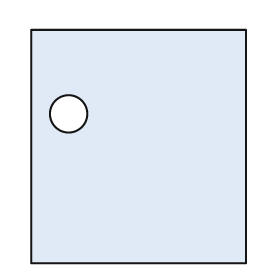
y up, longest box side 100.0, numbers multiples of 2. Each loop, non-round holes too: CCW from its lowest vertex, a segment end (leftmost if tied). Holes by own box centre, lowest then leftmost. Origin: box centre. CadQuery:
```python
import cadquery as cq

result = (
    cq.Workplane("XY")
    .moveTo(-46.0, -50.0)
    .lineTo(46.0, -50.0)
    .lineTo(46.0, 50.0)
    .lineTo(-46.0, 50.0)
    .close()
    .moveTo(-30.0, 14.0)
    .circle(8.0)
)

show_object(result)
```